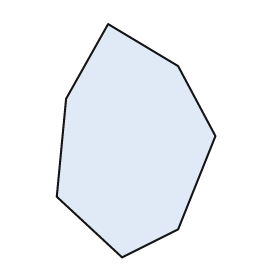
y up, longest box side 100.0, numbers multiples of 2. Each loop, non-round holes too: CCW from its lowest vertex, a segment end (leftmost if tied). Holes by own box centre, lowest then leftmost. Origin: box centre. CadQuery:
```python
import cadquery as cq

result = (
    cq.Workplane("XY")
    .moveTo(-6.0, -50.0)
    .lineTo(18.0, -38.0)
    .lineTo(34.0, 2.0)
    .lineTo(18.0, 32.0)
    .lineTo(-12.0, 50.0)
    .lineTo(-30.0, 18.0)
    .lineTo(-34.0, -24.0)
    .close()
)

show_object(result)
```